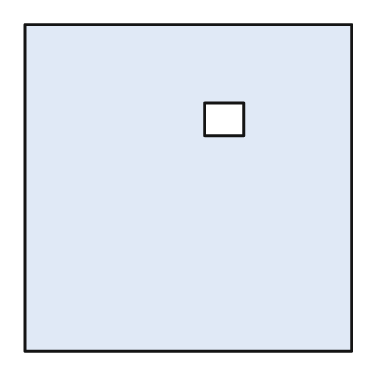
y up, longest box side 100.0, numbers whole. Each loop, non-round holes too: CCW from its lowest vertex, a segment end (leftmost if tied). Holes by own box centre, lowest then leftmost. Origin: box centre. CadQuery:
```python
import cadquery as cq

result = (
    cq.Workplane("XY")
    .moveTo(-50.0, -50.0)
    .lineTo(50.0, -50.0)
    .lineTo(50.0, 50.0)
    .lineTo(-50.0, 50.0)
    .close()
    .moveTo(5.0, 16.0)
    .lineTo(17.0, 16.0)
    .lineTo(17.0, 26.0)
    .lineTo(5.0, 26.0)
    .close()
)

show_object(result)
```